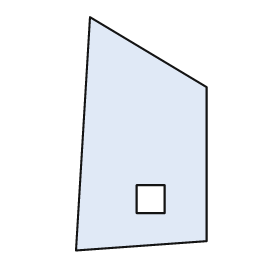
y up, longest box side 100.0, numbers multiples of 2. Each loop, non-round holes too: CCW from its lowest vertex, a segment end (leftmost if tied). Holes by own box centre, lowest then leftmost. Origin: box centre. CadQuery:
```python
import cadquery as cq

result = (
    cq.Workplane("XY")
    .moveTo(-28.0, -50.0)
    .lineTo(28.0, -46.0)
    .lineTo(28.0, 20.0)
    .lineTo(-22.0, 50.0)
    .close()
    .moveTo(-2.0, -34.0)
    .lineTo(10.0, -34.0)
    .lineTo(10.0, -22.0)
    .lineTo(-2.0, -22.0)
    .close()
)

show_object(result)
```